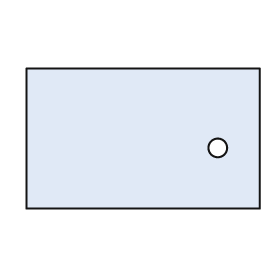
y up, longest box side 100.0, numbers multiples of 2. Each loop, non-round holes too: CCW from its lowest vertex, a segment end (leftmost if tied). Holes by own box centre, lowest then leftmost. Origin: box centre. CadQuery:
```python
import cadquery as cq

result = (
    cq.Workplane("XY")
    .moveTo(-50.0, -30.0)
    .lineTo(50.0, -30.0)
    .lineTo(50.0, 30.0)
    .lineTo(-50.0, 30.0)
    .close()
    .moveTo(32.0, -4.0)
    .circle(4.0)
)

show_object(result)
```